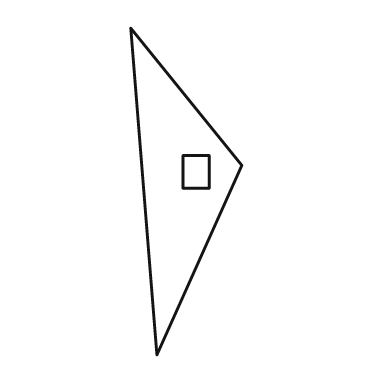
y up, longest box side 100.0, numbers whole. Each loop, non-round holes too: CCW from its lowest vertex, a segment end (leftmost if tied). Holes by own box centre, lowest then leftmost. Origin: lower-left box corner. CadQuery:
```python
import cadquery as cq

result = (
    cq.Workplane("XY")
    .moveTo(8.0, 0.0)
    .lineTo(34.0, 58.0)
    .lineTo(0.0, 100.0)
    .close()
    .moveTo(16.0, 51.0)
    .lineTo(24.0, 51.0)
    .lineTo(24.0, 61.0)
    .lineTo(16.0, 61.0)
    .close()
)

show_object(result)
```